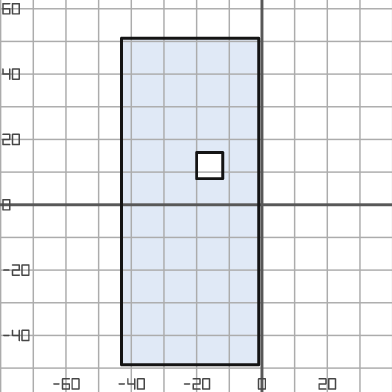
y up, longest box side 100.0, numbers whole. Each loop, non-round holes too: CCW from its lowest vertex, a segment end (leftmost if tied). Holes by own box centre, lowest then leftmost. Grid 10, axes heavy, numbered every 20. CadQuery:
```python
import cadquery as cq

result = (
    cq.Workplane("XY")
    .moveTo(-43.0, -49.0)
    .lineTo(-1.0, -49.0)
    .lineTo(-1.0, 51.0)
    .lineTo(-43.0, 51.0)
    .close()
    .moveTo(-20.0, 8.0)
    .lineTo(-12.0, 8.0)
    .lineTo(-12.0, 16.0)
    .lineTo(-20.0, 16.0)
    .close()
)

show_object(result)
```